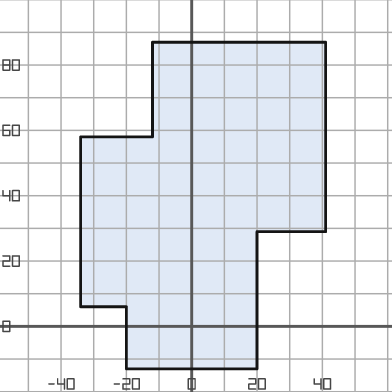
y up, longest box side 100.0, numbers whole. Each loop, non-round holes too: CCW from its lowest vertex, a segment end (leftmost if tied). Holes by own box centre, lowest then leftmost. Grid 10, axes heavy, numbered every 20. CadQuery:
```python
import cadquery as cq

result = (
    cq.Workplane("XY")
    .moveTo(-20.0, -13.0)
    .lineTo(20.0, -13.0)
    .lineTo(20.0, 29.0)
    .lineTo(41.0, 29.0)
    .lineTo(41.0, 87.0)
    .lineTo(-12.0, 87.0)
    .lineTo(-12.0, 58.0)
    .lineTo(-34.0, 58.0)
    .lineTo(-34.0, 6.0)
    .lineTo(-20.0, 6.0)
    .close()
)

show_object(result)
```